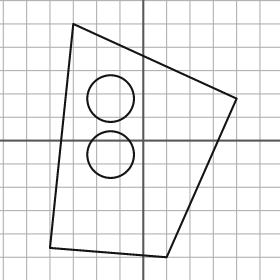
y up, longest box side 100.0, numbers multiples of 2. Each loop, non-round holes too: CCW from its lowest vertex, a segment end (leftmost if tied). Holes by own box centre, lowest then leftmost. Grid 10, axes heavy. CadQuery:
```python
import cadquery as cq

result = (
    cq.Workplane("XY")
    .moveTo(10.0, -50.0)
    .lineTo(40.0, 18.0)
    .lineTo(-30.0, 50.0)
    .lineTo(-40.0, -46.0)
    .close()
    .moveTo(-14.0, -6.0)
    .circle(10.0)
    .moveTo(-14.0, 18.0)
    .circle(10.0)
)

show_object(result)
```